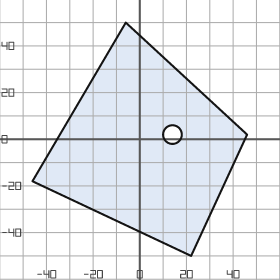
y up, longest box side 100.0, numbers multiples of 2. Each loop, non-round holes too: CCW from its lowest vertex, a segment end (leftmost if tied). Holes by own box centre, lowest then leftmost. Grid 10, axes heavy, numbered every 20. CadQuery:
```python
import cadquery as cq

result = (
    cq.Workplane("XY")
    .moveTo(22.0, -50.0)
    .lineTo(46.0, 2.0)
    .lineTo(-6.0, 50.0)
    .lineTo(-46.0, -18.0)
    .close()
    .moveTo(14.0, 2.0)
    .circle(4.0)
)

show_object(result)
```